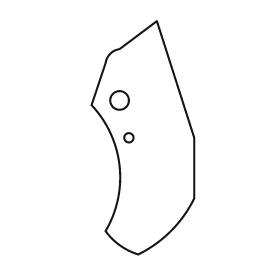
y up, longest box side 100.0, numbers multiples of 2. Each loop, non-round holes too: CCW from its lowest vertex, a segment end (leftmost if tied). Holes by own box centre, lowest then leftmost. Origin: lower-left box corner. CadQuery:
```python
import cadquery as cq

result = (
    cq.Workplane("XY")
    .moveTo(20.0, 0.0)
    .threePointArc((34.0, 10.0), (44.0, 24.0))
    .lineTo(44.0, 50.0)
    .lineTo(28.0, 100.0)
    .lineTo(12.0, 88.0)
    .threePointArc((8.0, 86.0), (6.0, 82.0))
    .lineTo(0.0, 64.0)
    .threePointArc((12.0, 38.0), (6.0, 10.0))
    .threePointArc((12.0, 4.0), (20.0, 0.0))
    .close()
    .moveTo(16.0, 50.0)
    .circle(2.0)
    .moveTo(12.0, 66.0)
    .circle(4.0)
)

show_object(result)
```